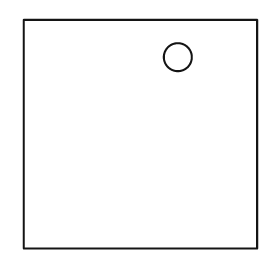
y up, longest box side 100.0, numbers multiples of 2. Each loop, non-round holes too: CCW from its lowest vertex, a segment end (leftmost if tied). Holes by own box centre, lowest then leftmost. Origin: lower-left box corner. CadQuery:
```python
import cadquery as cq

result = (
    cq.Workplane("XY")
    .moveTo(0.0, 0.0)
    .lineTo(100.0, 0.0)
    .lineTo(100.0, 98.0)
    .lineTo(0.0, 98.0)
    .close()
    .moveTo(66.0, 82.0)
    .circle(6.0)
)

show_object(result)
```